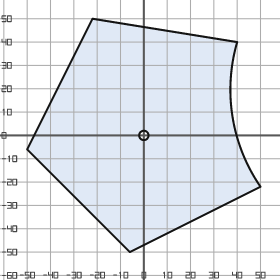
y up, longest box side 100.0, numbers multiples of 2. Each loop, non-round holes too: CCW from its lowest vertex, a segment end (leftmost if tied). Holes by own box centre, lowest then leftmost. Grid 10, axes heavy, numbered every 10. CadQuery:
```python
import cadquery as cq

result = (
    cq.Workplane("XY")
    .moveTo(-6.0, -50.0)
    .lineTo(50.0, -22.0)
    .threePointArc((38.0, 8.0), (40.0, 40.0))
    .lineTo(-22.0, 50.0)
    .lineTo(-50.0, -6.0)
    .close()
    .moveTo(0.0, 0.0)
    .circle(2.0)
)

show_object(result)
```